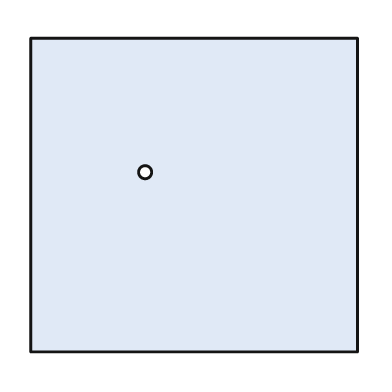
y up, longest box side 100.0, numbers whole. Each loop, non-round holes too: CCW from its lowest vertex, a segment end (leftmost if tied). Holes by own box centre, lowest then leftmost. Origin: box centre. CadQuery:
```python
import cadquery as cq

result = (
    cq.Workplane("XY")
    .moveTo(-50.0, -48.0)
    .lineTo(50.0, -48.0)
    .lineTo(50.0, 48.0)
    .lineTo(-50.0, 48.0)
    .close()
    .moveTo(-15.0, 7.0)
    .circle(2.0)
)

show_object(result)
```